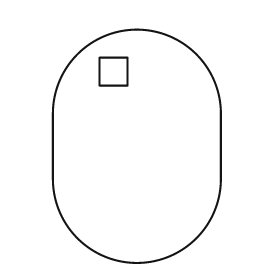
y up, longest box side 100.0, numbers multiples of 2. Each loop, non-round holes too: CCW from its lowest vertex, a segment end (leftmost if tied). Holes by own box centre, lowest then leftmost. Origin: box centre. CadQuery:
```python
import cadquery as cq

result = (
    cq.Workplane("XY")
    .moveTo(-36.0, -14.0)
    .threePointArc((0.0, -50.0), (36.0, -14.0))
    .lineTo(36.0, 14.0)
    .threePointArc((0.0, 50.0), (-36.0, 14.0))
    .close()
    .moveTo(-16.0, 26.0)
    .lineTo(-4.0, 26.0)
    .lineTo(-4.0, 38.0)
    .lineTo(-16.0, 38.0)
    .close()
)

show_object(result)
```